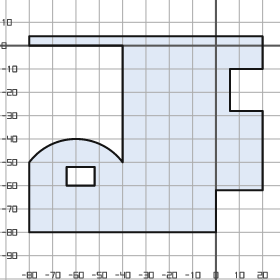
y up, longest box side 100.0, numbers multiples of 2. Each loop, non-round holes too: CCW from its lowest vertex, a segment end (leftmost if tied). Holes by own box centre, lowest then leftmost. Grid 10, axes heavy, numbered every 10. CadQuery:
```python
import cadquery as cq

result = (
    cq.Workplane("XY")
    .moveTo(-80.0, -80.0)
    .lineTo(0.0, -80.0)
    .lineTo(0.0, -62.0)
    .lineTo(20.0, -62.0)
    .lineTo(20.0, -28.0)
    .lineTo(6.0, -28.0)
    .lineTo(6.0, -10.0)
    .lineTo(20.0, -10.0)
    .lineTo(20.0, 4.0)
    .lineTo(-80.0, 4.0)
    .lineTo(-80.0, 0.0)
    .lineTo(-40.0, 0.0)
    .lineTo(-40.0, -50.0)
    .threePointArc((-60.0, -40.0), (-80.0, -50.0))
    .close()
    .moveTo(-64.0, -60.0)
    .lineTo(-52.0, -60.0)
    .lineTo(-52.0, -52.0)
    .lineTo(-64.0, -52.0)
    .close()
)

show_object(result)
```